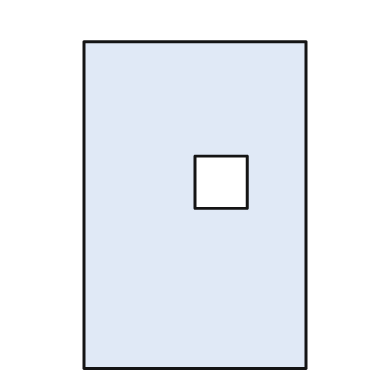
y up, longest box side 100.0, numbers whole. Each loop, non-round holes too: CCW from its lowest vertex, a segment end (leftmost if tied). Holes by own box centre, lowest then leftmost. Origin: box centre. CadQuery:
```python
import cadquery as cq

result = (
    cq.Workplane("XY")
    .moveTo(-34.0, -50.0)
    .lineTo(34.0, -50.0)
    .lineTo(34.0, 50.0)
    .lineTo(-34.0, 50.0)
    .close()
    .moveTo(0.0, -1.0)
    .lineTo(16.0, -1.0)
    .lineTo(16.0, 15.0)
    .lineTo(0.0, 15.0)
    .close()
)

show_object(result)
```